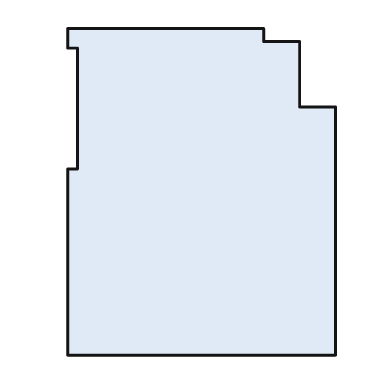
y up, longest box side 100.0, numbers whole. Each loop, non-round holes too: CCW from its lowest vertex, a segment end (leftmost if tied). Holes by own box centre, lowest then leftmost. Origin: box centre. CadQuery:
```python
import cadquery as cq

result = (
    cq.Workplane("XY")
    .moveTo(-41.0, -50.0)
    .lineTo(41.0, -50.0)
    .lineTo(41.0, 26.0)
    .lineTo(30.0, 26.0)
    .lineTo(30.0, 46.0)
    .lineTo(19.0, 46.0)
    .lineTo(19.0, 50.0)
    .lineTo(-41.0, 50.0)
    .lineTo(-41.0, 44.0)
    .lineTo(-38.0, 44.0)
    .lineTo(-38.0, 7.0)
    .lineTo(-41.0, 7.0)
    .close()
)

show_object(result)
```